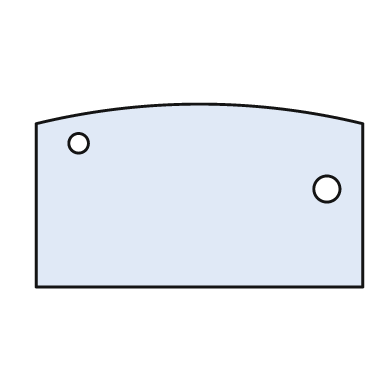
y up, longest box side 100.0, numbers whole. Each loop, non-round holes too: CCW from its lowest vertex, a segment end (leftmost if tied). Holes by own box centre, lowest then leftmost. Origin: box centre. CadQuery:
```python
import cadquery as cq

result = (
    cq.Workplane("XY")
    .moveTo(-50.0, -28.0)
    .lineTo(50.0, -28.0)
    .lineTo(50.0, 22.0)
    .threePointArc((0.0, 28.0), (-50.0, 22.0))
    .close()
    .moveTo(39.0, 2.0)
    .circle(4.0)
    .moveTo(-37.0, 16.0)
    .circle(3.0)
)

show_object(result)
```